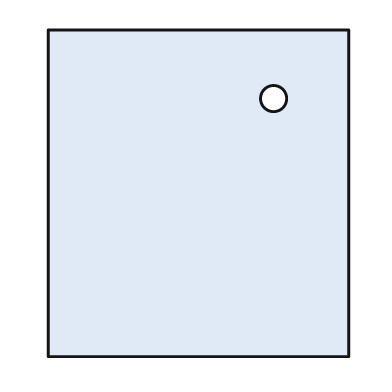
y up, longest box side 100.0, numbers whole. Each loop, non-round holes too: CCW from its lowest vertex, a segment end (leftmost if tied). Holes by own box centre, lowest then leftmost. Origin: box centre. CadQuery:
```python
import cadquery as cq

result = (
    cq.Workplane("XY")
    .moveTo(-46.0, -50.0)
    .lineTo(46.0, -50.0)
    .lineTo(46.0, 50.0)
    .lineTo(-46.0, 50.0)
    .close()
    .moveTo(23.0, 29.0)
    .circle(4.0)
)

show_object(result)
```